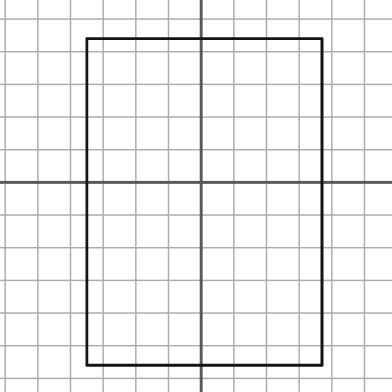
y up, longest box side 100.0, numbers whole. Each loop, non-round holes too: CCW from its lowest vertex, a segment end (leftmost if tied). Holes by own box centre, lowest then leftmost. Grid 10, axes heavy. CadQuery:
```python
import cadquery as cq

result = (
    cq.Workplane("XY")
    .moveTo(-35.0, -56.0)
    .lineTo(37.0, -56.0)
    .lineTo(37.0, 44.0)
    .lineTo(-35.0, 44.0)
    .close()
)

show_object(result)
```